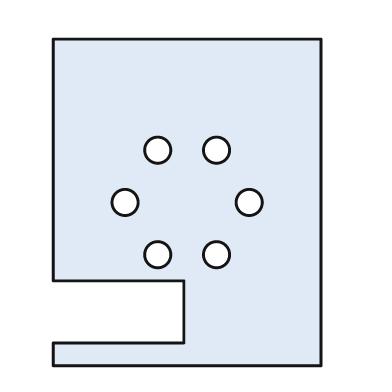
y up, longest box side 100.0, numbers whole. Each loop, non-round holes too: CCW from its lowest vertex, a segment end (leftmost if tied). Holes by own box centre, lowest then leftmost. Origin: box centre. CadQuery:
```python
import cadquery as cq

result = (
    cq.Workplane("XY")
    .moveTo(-41.0, -50.0)
    .lineTo(41.0, -50.0)
    .lineTo(41.0, 50.0)
    .lineTo(-41.0, 50.0)
    .lineTo(-41.0, -24.0)
    .lineTo(-1.0, -24.0)
    .lineTo(-1.0, -43.0)
    .lineTo(-41.0, -43.0)
    .close()
    .moveTo(-9.0, -16.0)
    .circle(4.0)
    .moveTo(9.0, -16.0)
    .circle(4.0)
    .moveTo(-19.0, 0.0)
    .circle(4.0)
    .moveTo(19.0, 0.0)
    .circle(4.0)
    .moveTo(-9.0, 16.0)
    .circle(4.0)
    .moveTo(9.0, 16.0)
    .circle(4.0)
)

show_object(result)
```